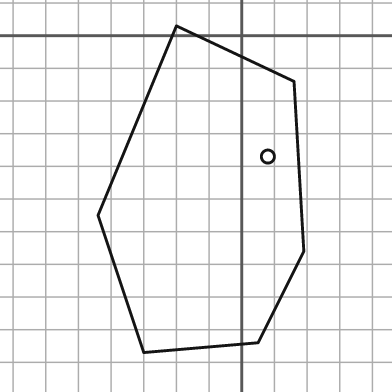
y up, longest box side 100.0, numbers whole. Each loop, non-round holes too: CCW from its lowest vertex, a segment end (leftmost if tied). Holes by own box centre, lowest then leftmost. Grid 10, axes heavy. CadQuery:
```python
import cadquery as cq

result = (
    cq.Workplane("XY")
    .moveTo(-30.0, -97.0)
    .lineTo(5.0, -94.0)
    .lineTo(19.0, -66.0)
    .lineTo(16.0, -14.0)
    .lineTo(-20.0, 3.0)
    .lineTo(-44.0, -55.0)
    .close()
    .moveTo(8.0, -37.0)
    .circle(2.0)
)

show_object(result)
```